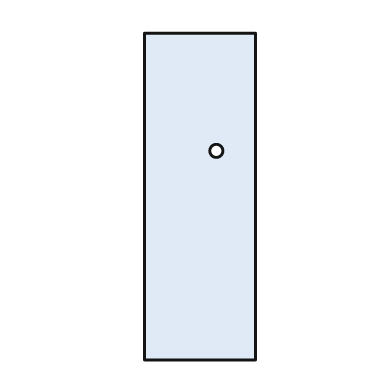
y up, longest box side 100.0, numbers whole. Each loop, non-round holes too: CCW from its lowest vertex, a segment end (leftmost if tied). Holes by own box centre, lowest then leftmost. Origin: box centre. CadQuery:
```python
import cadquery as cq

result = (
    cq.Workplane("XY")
    .moveTo(-17.0, -50.0)
    .lineTo(17.0, -50.0)
    .lineTo(17.0, 50.0)
    .lineTo(-17.0, 50.0)
    .close()
    .moveTo(5.0, 14.0)
    .circle(2.0)
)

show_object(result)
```